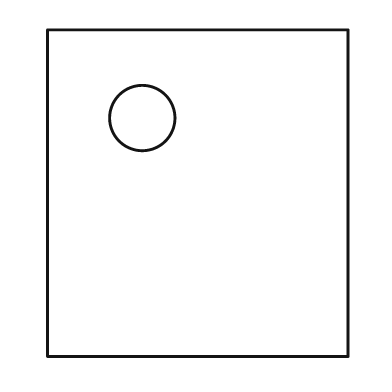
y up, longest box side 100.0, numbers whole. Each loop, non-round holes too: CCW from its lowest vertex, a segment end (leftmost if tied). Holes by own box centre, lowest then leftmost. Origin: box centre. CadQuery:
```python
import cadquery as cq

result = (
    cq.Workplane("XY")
    .moveTo(-46.0, -50.0)
    .lineTo(46.0, -50.0)
    .lineTo(46.0, 50.0)
    .lineTo(-46.0, 50.0)
    .close()
    .moveTo(-17.0, 23.0)
    .circle(10.0)
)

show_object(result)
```